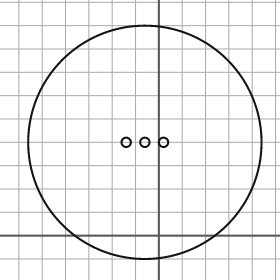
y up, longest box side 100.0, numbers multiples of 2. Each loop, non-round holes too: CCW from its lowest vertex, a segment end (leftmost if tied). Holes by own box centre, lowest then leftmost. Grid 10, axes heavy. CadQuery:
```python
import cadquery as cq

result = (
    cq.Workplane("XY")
    .moveTo(-6.0, 40.0)
    .circle(50.0)
    .moveTo(-14.0, 40.0)
    .circle(2.0)
    .moveTo(-6.0, 40.0)
    .circle(2.0)
    .moveTo(2.0, 40.0)
    .circle(2.0)
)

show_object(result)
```